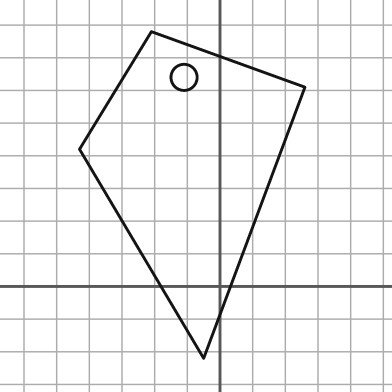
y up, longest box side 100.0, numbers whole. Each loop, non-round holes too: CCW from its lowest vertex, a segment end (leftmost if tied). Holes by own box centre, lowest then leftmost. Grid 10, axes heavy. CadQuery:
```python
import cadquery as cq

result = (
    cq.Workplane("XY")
    .moveTo(-5.0, -22.0)
    .lineTo(26.0, 61.0)
    .lineTo(-21.0, 78.0)
    .lineTo(-43.0, 42.0)
    .close()
    .moveTo(-11.0, 64.0)
    .circle(4.0)
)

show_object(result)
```